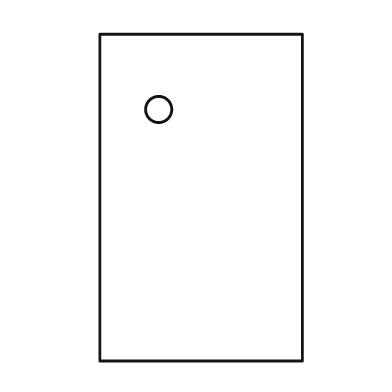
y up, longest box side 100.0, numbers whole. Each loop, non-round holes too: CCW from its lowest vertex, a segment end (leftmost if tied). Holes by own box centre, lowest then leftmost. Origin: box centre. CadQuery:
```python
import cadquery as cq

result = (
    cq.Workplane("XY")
    .moveTo(-31.0, -50.0)
    .lineTo(31.0, -50.0)
    .lineTo(31.0, 50.0)
    .lineTo(-31.0, 50.0)
    .close()
    .moveTo(-13.0, 27.0)
    .circle(4.0)
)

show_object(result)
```